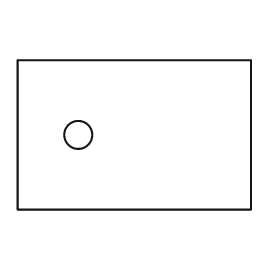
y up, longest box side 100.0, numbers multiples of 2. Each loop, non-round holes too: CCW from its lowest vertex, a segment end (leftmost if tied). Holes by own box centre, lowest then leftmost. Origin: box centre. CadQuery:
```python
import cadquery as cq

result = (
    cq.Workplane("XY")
    .moveTo(-50.0, -32.0)
    .lineTo(50.0, -32.0)
    .lineTo(50.0, 32.0)
    .lineTo(-50.0, 32.0)
    .close()
    .moveTo(-24.0, 0.0)
    .circle(6.0)
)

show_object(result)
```